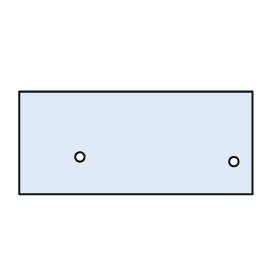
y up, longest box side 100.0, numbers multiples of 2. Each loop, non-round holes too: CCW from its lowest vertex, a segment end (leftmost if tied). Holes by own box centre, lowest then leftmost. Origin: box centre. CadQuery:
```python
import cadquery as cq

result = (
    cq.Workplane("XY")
    .moveTo(-50.0, -22.0)
    .lineTo(50.0, -22.0)
    .lineTo(50.0, 22.0)
    .lineTo(-50.0, 22.0)
    .close()
    .moveTo(42.0, -8.0)
    .circle(2.0)
    .moveTo(-24.0, -6.0)
    .circle(2.0)
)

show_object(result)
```